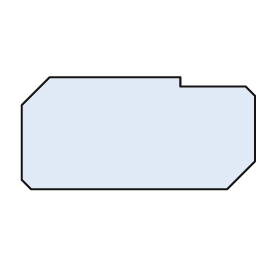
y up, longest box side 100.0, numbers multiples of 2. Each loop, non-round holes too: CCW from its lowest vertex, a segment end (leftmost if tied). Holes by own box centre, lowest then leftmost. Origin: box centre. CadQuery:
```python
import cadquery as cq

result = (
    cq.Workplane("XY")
    .moveTo(-46.0, -24.0)
    .lineTo(38.0, -24.0)
    .lineTo(50.0, -12.0)
    .lineTo(50.0, 16.0)
    .lineTo(46.0, 20.0)
    .lineTo(18.0, 20.0)
    .lineTo(18.0, 24.0)
    .lineTo(-38.0, 24.0)
    .lineTo(-50.0, 12.0)
    .lineTo(-50.0, -20.0)
    .close()
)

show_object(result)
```